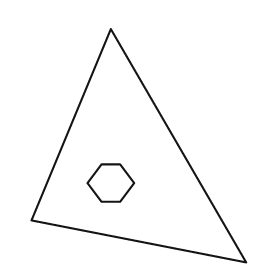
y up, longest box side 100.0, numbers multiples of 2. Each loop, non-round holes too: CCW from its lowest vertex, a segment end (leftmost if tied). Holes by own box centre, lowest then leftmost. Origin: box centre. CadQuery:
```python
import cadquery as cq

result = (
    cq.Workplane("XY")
    .moveTo(46.0, -50.0)
    .lineTo(-12.0, 50.0)
    .lineTo(-46.0, -32.0)
    .close()
    .moveTo(-16.0, -24.0)
    .lineTo(-8.0, -24.0)
    .lineTo(-2.0, -16.0)
    .lineTo(-8.0, -8.0)
    .lineTo(-16.0, -8.0)
    .lineTo(-22.0, -16.0)
    .close()
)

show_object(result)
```